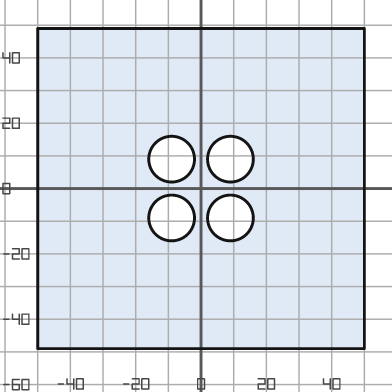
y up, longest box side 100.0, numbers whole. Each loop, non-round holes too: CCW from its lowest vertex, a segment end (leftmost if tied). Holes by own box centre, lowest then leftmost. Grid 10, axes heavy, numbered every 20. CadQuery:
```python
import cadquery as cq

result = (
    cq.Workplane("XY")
    .moveTo(-50.0, -49.0)
    .lineTo(50.0, -49.0)
    .lineTo(50.0, 49.0)
    .lineTo(-50.0, 49.0)
    .close()
    .moveTo(-9.0, -9.0)
    .circle(7.0)
    .moveTo(9.0, -9.0)
    .circle(7.0)
    .moveTo(-9.0, 9.0)
    .circle(7.0)
    .moveTo(9.0, 9.0)
    .circle(7.0)
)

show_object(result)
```